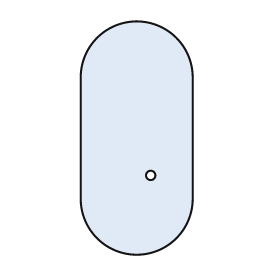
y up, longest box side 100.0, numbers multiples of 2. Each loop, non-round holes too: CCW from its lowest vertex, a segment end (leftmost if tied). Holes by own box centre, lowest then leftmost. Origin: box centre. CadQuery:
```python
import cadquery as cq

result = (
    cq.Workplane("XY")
    .moveTo(-24.0, -26.0)
    .threePointArc((0.0, -50.0), (24.0, -26.0))
    .lineTo(24.0, 26.0)
    .threePointArc((0.0, 50.0), (-24.0, 26.0))
    .close()
    .moveTo(6.0, -16.0)
    .circle(2.0)
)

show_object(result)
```